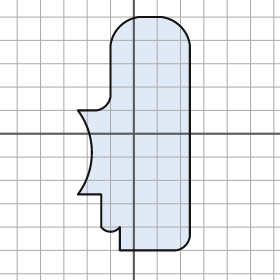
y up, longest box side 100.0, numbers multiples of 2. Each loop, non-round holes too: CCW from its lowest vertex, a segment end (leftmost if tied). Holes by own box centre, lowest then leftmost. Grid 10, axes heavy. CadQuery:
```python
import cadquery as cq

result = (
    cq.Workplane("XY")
    .moveTo(-6.0, -50.0)
    .lineTo(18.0, -50.0)
    .threePointArc((22.0, -48.0), (24.0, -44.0))
    .lineTo(24.0, 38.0)
    .threePointArc((20.0, 46.0), (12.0, 50.0))
    .lineTo(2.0, 50.0)
    .threePointArc((-6.0, 46.0), (-10.0, 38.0))
    .lineTo(-10.0, 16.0)
    .threePointArc((-12.0, 12.0), (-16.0, 10.0))
    .lineTo(-24.0, 10.0)
    .threePointArc((-18.0, -8.0), (-24.0, -26.0))
    .lineTo(-14.0, -26.0)
    .lineTo(-14.0, -40.0)
    .threePointArc((-10.0, -42.0), (-6.0, -40.0))
    .close()
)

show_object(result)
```